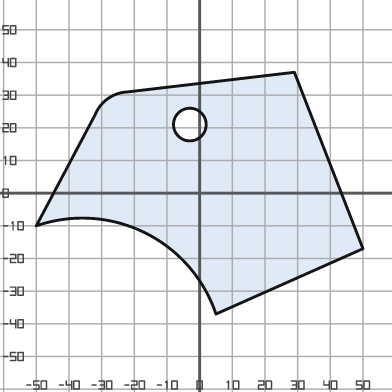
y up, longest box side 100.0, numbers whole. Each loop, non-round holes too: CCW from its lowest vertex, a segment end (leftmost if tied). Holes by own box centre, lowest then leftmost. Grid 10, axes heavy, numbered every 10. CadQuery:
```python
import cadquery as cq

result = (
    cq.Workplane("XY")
    .moveTo(5.0, -37.0)
    .lineTo(50.0, -17.0)
    .lineTo(29.0, 37.0)
    .lineTo(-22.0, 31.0)
    .threePointArc((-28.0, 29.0), (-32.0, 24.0))
    .lineTo(-50.0, -10.0)
    .threePointArc((-17.0, -12.0), (5.0, -37.0))
    .close()
    .moveTo(-3.0, 21.0)
    .circle(5.0)
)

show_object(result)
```